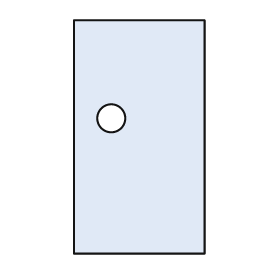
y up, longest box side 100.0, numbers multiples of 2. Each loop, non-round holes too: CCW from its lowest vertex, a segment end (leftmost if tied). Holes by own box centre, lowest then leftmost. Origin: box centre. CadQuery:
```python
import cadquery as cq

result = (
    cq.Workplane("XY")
    .moveTo(-28.0, -50.0)
    .lineTo(28.0, -50.0)
    .lineTo(28.0, 50.0)
    .lineTo(-28.0, 50.0)
    .close()
    .moveTo(-12.0, 8.0)
    .circle(6.0)
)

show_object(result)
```